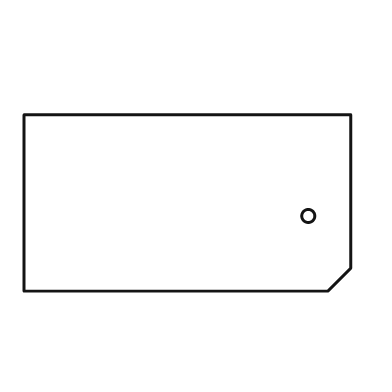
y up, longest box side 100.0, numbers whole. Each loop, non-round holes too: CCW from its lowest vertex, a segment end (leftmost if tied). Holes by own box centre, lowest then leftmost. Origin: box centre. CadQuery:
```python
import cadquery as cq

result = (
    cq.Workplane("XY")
    .moveTo(-50.0, -27.0)
    .lineTo(43.0, -27.0)
    .lineTo(50.0, -20.0)
    .lineTo(50.0, 27.0)
    .lineTo(-50.0, 27.0)
    .close()
    .moveTo(37.0, -4.0)
    .circle(2.0)
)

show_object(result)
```